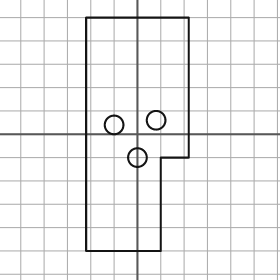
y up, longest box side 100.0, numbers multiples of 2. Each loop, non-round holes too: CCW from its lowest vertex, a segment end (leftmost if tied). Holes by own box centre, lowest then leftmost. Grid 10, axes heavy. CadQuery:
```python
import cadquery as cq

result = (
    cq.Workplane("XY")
    .moveTo(-22.0, -50.0)
    .lineTo(10.0, -50.0)
    .lineTo(10.0, -10.0)
    .lineTo(22.0, -10.0)
    .lineTo(22.0, 50.0)
    .lineTo(-22.0, 50.0)
    .close()
    .moveTo(0.0, -10.0)
    .circle(4.0)
    .moveTo(-10.0, 4.0)
    .circle(4.0)
    .moveTo(8.0, 6.0)
    .circle(4.0)
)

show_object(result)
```